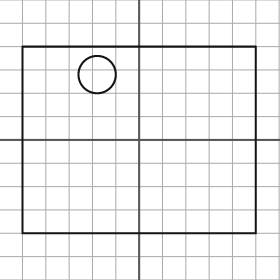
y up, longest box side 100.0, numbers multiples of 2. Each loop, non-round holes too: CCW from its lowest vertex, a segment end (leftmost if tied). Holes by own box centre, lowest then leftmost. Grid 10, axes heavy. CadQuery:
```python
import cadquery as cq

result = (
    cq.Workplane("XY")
    .moveTo(-50.0, -40.0)
    .lineTo(50.0, -40.0)
    .lineTo(50.0, 40.0)
    .lineTo(-50.0, 40.0)
    .close()
    .moveTo(-18.0, 28.0)
    .circle(8.0)
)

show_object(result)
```